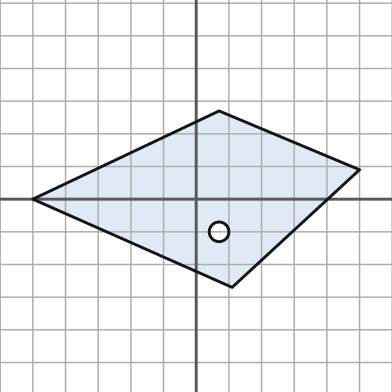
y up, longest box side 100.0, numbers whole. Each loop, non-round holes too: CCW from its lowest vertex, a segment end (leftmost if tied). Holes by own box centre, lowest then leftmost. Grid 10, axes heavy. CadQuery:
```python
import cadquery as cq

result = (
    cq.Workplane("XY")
    .moveTo(11.0, -27.0)
    .lineTo(50.0, 9.0)
    .lineTo(7.0, 27.0)
    .lineTo(-50.0, 0.0)
    .close()
    .moveTo(7.0, -10.0)
    .circle(3.0)
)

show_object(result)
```